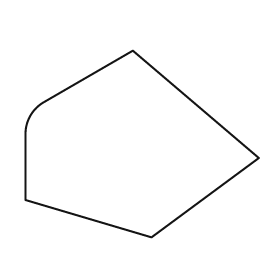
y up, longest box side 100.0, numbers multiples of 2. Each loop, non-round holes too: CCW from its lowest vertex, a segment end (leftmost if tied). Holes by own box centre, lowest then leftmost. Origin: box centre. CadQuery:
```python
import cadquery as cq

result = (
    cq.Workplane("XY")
    .moveTo(4.0, -40.0)
    .lineTo(50.0, -6.0)
    .lineTo(-4.0, 40.0)
    .lineTo(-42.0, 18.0)
    .threePointArc((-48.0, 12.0), (-50.0, 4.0))
    .lineTo(-50.0, -24.0)
    .close()
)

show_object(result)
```